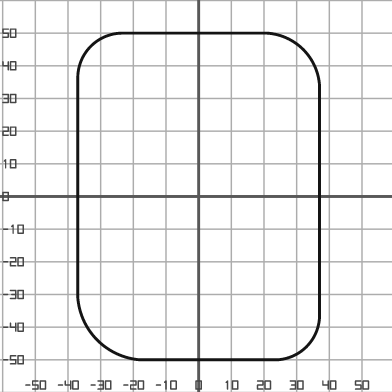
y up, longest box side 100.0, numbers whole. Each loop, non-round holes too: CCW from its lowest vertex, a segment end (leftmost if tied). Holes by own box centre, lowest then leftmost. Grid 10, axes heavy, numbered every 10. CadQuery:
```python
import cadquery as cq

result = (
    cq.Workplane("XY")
    .moveTo(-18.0, -50.0)
    .lineTo(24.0, -50.0)
    .threePointArc((33.0, -46.0), (37.0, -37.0))
    .lineTo(37.0, 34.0)
    .threePointArc((32.0, 45.0), (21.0, 50.0))
    .lineTo(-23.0, 50.0)
    .threePointArc((-33.0, 46.0), (-37.0, 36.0))
    .lineTo(-37.0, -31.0)
    .threePointArc((-31.0, -44.0), (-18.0, -50.0))
    .close()
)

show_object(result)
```